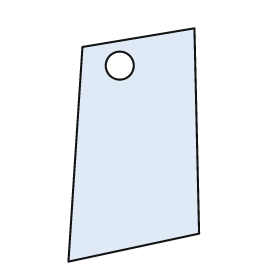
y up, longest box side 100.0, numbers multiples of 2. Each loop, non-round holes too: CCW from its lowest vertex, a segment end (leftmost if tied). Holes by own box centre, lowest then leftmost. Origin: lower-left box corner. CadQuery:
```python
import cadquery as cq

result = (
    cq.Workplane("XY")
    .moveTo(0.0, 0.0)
    .lineTo(56.0, 12.0)
    .lineTo(54.0, 100.0)
    .lineTo(6.0, 92.0)
    .close()
    .moveTo(22.0, 84.0)
    .circle(6.0)
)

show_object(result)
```